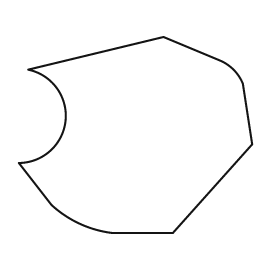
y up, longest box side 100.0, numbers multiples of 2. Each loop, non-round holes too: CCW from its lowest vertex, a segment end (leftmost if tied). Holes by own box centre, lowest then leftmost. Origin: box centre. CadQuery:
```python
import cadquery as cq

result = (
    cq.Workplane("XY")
    .moveTo(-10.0, -42.0)
    .lineTo(16.0, -42.0)
    .lineTo(50.0, -4.0)
    .lineTo(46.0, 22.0)
    .threePointArc((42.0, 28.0), (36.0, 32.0))
    .lineTo(12.0, 42.0)
    .lineTo(-46.0, 28.0)
    .threePointArc((-30.0, 6.0), (-50.0, -12.0))
    .lineTo(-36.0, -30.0)
    .threePointArc((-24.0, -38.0), (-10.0, -42.0))
    .close()
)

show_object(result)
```